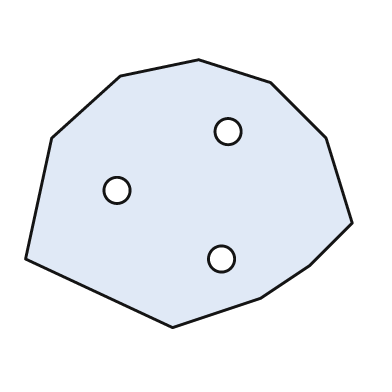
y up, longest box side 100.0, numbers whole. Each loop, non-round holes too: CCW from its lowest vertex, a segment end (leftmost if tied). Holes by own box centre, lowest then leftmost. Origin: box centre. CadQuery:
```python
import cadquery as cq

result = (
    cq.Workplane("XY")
    .moveTo(-5.0, -41.0)
    .lineTo(22.0, -32.0)
    .lineTo(37.0, -22.0)
    .lineTo(50.0, -9.0)
    .lineTo(42.0, 17.0)
    .lineTo(25.0, 34.0)
    .lineTo(3.0, 41.0)
    .lineTo(-21.0, 36.0)
    .lineTo(-42.0, 17.0)
    .lineTo(-50.0, -20.0)
    .close()
    .moveTo(10.0, -20.0)
    .circle(4.0)
    .moveTo(-22.0, 1.0)
    .circle(4.0)
    .moveTo(12.0, 19.0)
    .circle(4.0)
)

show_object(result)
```